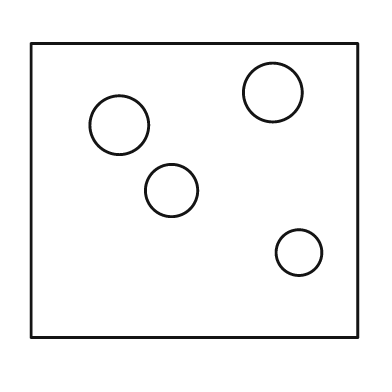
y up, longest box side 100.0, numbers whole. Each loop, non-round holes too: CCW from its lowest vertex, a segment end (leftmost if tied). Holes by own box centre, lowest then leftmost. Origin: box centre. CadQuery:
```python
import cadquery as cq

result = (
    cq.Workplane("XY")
    .moveTo(-50.0, -45.0)
    .lineTo(50.0, -45.0)
    .lineTo(50.0, 45.0)
    .lineTo(-50.0, 45.0)
    .close()
    .moveTo(32.0, -19.0)
    .circle(7.0)
    .moveTo(-7.0, 0.0)
    .circle(8.0)
    .moveTo(-23.0, 20.0)
    .circle(9.0)
    .moveTo(24.0, 30.0)
    .circle(9.0)
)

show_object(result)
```